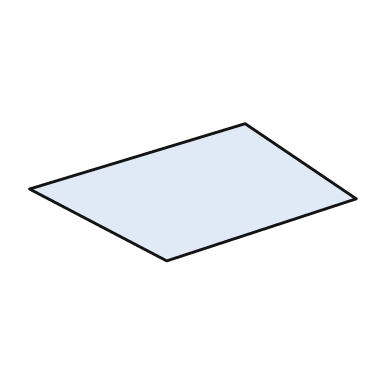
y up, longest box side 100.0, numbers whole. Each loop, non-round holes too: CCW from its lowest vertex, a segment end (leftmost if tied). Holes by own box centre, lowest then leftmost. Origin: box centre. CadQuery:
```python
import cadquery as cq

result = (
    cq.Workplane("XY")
    .moveTo(-8.0, -21.0)
    .lineTo(50.0, -2.0)
    .lineTo(16.0, 21.0)
    .lineTo(-50.0, 1.0)
    .close()
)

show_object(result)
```